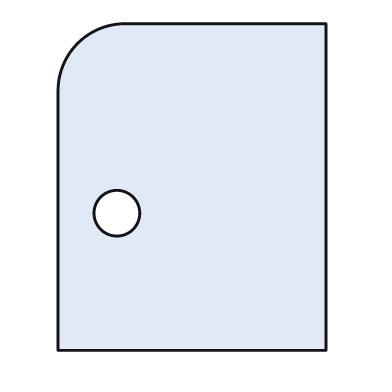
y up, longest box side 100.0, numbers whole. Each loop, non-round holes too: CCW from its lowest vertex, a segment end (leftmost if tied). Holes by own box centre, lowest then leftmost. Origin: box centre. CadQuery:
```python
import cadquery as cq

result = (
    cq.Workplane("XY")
    .moveTo(-41.0, -50.0)
    .lineTo(41.0, -50.0)
    .lineTo(41.0, 50.0)
    .lineTo(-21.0, 50.0)
    .threePointArc((-35.0, 44.0), (-41.0, 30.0))
    .close()
    .moveTo(-23.0, -8.0)
    .circle(7.0)
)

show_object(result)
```